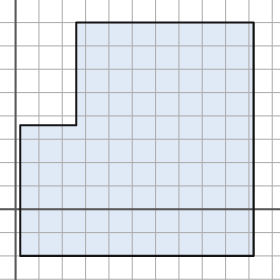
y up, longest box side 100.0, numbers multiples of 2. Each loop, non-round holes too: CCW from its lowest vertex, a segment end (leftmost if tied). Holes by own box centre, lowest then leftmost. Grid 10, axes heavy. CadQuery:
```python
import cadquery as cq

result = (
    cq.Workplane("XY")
    .moveTo(2.0, -20.0)
    .lineTo(102.0, -20.0)
    .lineTo(102.0, 80.0)
    .lineTo(26.0, 80.0)
    .lineTo(26.0, 36.0)
    .lineTo(2.0, 36.0)
    .close()
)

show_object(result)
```